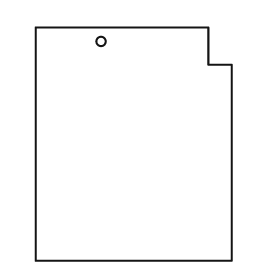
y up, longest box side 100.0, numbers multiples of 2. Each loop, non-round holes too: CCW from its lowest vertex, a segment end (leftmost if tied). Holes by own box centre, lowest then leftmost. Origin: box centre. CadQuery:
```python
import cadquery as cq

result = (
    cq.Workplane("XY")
    .moveTo(-42.0, -50.0)
    .lineTo(42.0, -50.0)
    .lineTo(42.0, 34.0)
    .lineTo(32.0, 34.0)
    .lineTo(32.0, 50.0)
    .lineTo(-42.0, 50.0)
    .close()
    .moveTo(-14.0, 44.0)
    .circle(2.0)
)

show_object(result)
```